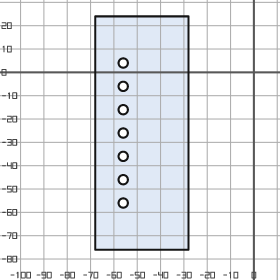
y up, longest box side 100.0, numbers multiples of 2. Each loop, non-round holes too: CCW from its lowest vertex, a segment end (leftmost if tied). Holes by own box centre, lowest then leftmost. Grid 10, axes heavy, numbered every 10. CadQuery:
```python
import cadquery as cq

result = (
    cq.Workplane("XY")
    .moveTo(-68.0, -76.0)
    .lineTo(-28.0, -76.0)
    .lineTo(-28.0, 24.0)
    .lineTo(-68.0, 24.0)
    .close()
    .moveTo(-56.0, -56.0)
    .circle(2.0)
    .moveTo(-56.0, -46.0)
    .circle(2.0)
    .moveTo(-56.0, -36.0)
    .circle(2.0)
    .moveTo(-56.0, -26.0)
    .circle(2.0)
    .moveTo(-56.0, -16.0)
    .circle(2.0)
    .moveTo(-56.0, -6.0)
    .circle(2.0)
    .moveTo(-56.0, 4.0)
    .circle(2.0)
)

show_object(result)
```